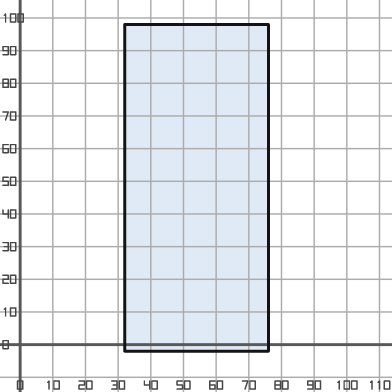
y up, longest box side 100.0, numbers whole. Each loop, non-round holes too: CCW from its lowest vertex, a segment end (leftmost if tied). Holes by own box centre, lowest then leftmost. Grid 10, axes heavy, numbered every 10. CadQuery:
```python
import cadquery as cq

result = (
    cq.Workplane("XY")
    .moveTo(32.0, -2.0)
    .lineTo(76.0, -2.0)
    .lineTo(76.0, 98.0)
    .lineTo(32.0, 98.0)
    .close()
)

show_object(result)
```